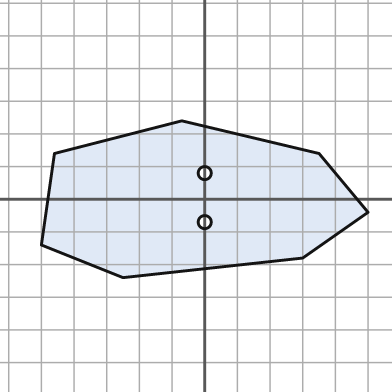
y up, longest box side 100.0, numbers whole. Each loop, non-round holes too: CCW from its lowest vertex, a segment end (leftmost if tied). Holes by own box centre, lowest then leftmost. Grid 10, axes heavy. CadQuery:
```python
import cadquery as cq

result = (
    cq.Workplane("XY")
    .moveTo(-25.0, -24.0)
    .lineTo(30.0, -18.0)
    .lineTo(50.0, -4.0)
    .lineTo(35.0, 14.0)
    .lineTo(-7.0, 24.0)
    .lineTo(-46.0, 14.0)
    .lineTo(-50.0, -14.0)
    .close()
    .moveTo(0.0, -7.0)
    .circle(2.0)
    .moveTo(0.0, 8.0)
    .circle(2.0)
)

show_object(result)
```